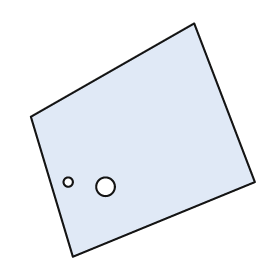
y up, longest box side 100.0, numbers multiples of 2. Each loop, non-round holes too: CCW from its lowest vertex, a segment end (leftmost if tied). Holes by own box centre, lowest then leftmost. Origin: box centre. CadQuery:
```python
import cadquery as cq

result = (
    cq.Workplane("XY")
    .moveTo(-30.0, -50.0)
    .lineTo(48.0, -18.0)
    .lineTo(22.0, 50.0)
    .lineTo(-48.0, 10.0)
    .close()
    .moveTo(-16.0, -20.0)
    .circle(4.0)
    .moveTo(-32.0, -18.0)
    .circle(2.0)
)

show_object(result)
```